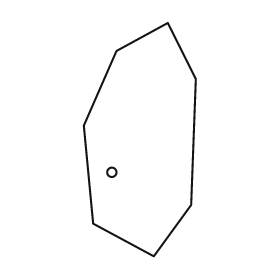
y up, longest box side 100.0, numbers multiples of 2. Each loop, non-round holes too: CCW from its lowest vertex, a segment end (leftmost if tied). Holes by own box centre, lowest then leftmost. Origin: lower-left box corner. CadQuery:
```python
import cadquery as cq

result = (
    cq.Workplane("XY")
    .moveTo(30.0, 0.0)
    .lineTo(46.0, 22.0)
    .lineTo(48.0, 76.0)
    .lineTo(36.0, 100.0)
    .lineTo(14.0, 88.0)
    .lineTo(0.0, 56.0)
    .lineTo(4.0, 14.0)
    .close()
    .moveTo(12.0, 36.0)
    .circle(2.0)
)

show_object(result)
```